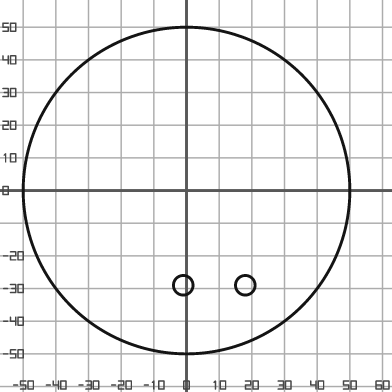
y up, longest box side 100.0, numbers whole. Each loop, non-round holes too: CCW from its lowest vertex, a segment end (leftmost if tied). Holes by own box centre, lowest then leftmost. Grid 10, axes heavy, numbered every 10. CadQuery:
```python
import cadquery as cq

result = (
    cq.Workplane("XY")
    .moveTo(0.0, 0.0)
    .circle(50.0)
    .moveTo(-1.0, -29.0)
    .circle(3.0)
    .moveTo(18.0, -29.0)
    .circle(3.0)
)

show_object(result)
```